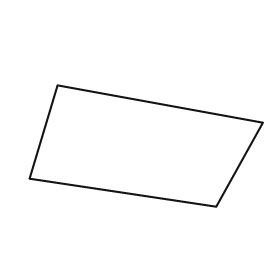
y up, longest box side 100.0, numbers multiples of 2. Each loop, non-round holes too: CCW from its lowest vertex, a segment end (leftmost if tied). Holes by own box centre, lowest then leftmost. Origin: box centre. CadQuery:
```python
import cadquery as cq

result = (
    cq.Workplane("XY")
    .moveTo(30.0, -26.0)
    .lineTo(50.0, 10.0)
    .lineTo(-38.0, 26.0)
    .lineTo(-50.0, -14.0)
    .close()
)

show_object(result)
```